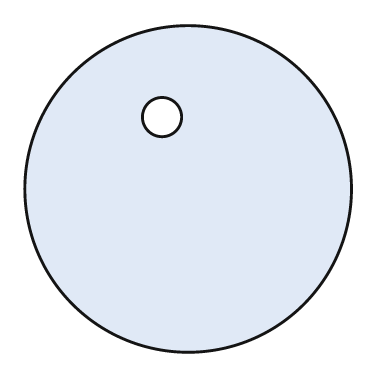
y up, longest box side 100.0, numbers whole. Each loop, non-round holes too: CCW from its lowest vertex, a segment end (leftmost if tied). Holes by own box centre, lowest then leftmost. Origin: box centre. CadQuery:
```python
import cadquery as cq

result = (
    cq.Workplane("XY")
    .moveTo(0.0, 0.0)
    .circle(50.0)
    .moveTo(-8.0, 22.0)
    .circle(6.0)
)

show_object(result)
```